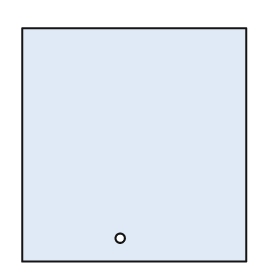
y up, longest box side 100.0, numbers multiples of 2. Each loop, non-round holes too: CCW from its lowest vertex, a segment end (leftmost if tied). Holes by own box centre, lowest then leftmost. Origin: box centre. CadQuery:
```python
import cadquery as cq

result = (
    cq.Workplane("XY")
    .moveTo(-48.0, -50.0)
    .lineTo(48.0, -50.0)
    .lineTo(48.0, 50.0)
    .lineTo(-48.0, 50.0)
    .close()
    .moveTo(-6.0, -40.0)
    .circle(2.0)
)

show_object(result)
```